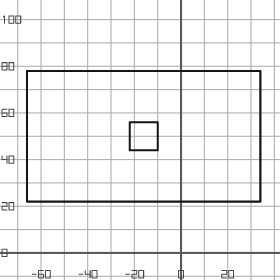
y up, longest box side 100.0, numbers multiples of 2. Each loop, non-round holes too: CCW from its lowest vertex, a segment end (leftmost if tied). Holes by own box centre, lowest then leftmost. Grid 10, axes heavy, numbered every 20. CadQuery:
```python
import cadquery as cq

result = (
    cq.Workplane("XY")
    .moveTo(-66.0, 22.0)
    .lineTo(34.0, 22.0)
    .lineTo(34.0, 78.0)
    .lineTo(-66.0, 78.0)
    .close()
    .moveTo(-22.0, 44.0)
    .lineTo(-10.0, 44.0)
    .lineTo(-10.0, 56.0)
    .lineTo(-22.0, 56.0)
    .close()
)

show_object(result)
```